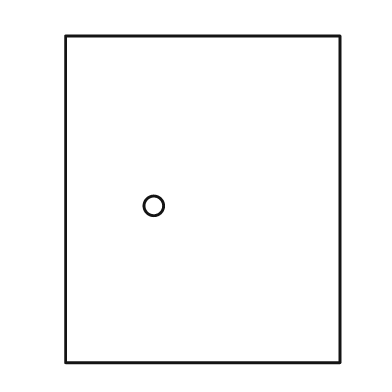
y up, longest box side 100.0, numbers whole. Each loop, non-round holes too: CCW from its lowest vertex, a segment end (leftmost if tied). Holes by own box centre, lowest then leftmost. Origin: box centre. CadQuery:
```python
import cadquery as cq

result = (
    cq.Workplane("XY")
    .moveTo(-42.0, -50.0)
    .lineTo(42.0, -50.0)
    .lineTo(42.0, 50.0)
    .lineTo(-42.0, 50.0)
    .close()
    .moveTo(-15.0, -2.0)
    .circle(3.0)
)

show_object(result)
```